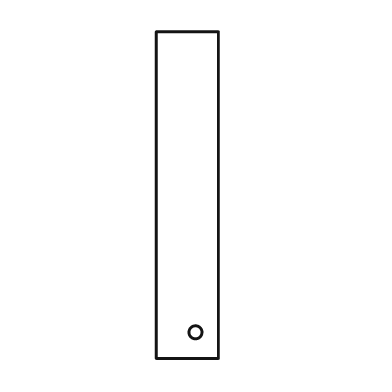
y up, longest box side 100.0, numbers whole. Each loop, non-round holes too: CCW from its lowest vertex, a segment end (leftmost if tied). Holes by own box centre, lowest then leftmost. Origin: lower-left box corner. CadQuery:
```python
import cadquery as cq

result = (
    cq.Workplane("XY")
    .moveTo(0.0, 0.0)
    .lineTo(19.0, 0.0)
    .lineTo(19.0, 100.0)
    .lineTo(0.0, 100.0)
    .close()
    .moveTo(12.0, 8.0)
    .circle(2.0)
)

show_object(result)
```